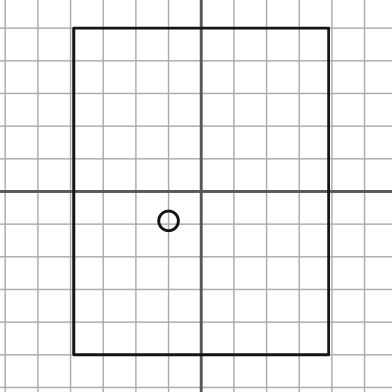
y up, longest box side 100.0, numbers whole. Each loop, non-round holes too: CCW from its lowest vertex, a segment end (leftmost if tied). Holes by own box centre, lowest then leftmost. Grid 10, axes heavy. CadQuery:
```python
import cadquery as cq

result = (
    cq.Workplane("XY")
    .moveTo(-39.0, -50.0)
    .lineTo(39.0, -50.0)
    .lineTo(39.0, 50.0)
    .lineTo(-39.0, 50.0)
    .close()
    .moveTo(-10.0, -9.0)
    .circle(3.0)
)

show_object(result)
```